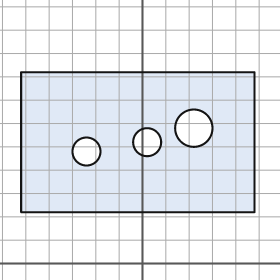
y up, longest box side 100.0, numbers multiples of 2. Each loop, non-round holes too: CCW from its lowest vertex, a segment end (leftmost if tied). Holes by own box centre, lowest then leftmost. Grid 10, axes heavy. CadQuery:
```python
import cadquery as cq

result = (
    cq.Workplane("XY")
    .moveTo(-52.0, 22.0)
    .lineTo(48.0, 22.0)
    .lineTo(48.0, 82.0)
    .lineTo(-52.0, 82.0)
    .close()
    .moveTo(-24.0, 48.0)
    .circle(6.0)
    .moveTo(2.0, 52.0)
    .circle(6.0)
    .moveTo(22.0, 58.0)
    .circle(8.0)
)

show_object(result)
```